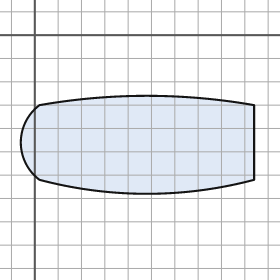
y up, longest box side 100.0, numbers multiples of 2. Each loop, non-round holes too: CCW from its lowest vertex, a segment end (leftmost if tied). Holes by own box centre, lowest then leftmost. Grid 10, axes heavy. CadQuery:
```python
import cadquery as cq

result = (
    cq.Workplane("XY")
    .moveTo(2.0, -62.0)
    .threePointArc((48.0, -68.0), (94.0, -62.0))
    .lineTo(94.0, -30.0)
    .threePointArc((48.0, -26.0), (2.0, -30.0))
    .threePointArc((-6.0, -46.0), (2.0, -62.0))
    .close()
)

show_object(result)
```